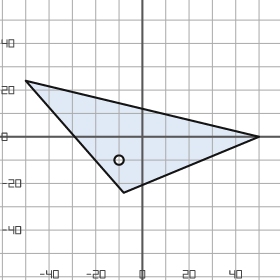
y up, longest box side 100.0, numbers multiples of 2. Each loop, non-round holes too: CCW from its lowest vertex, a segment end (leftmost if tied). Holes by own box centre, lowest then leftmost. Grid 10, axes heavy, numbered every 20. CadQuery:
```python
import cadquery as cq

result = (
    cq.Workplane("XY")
    .moveTo(-8.0, -24.0)
    .lineTo(50.0, 0.0)
    .lineTo(-50.0, 24.0)
    .close()
    .moveTo(-10.0, -10.0)
    .circle(2.0)
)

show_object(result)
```